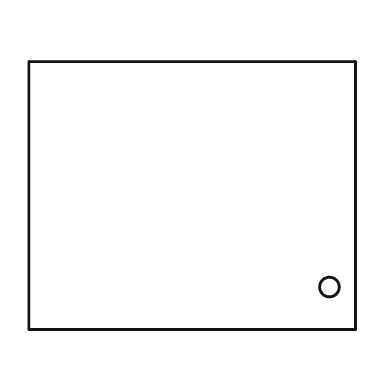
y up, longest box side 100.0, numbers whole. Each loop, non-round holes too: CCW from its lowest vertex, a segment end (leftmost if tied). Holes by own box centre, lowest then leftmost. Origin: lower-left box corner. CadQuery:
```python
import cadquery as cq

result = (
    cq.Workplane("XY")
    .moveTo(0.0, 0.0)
    .lineTo(100.0, 0.0)
    .lineTo(100.0, 82.0)
    .lineTo(0.0, 82.0)
    .close()
    .moveTo(92.0, 13.0)
    .circle(3.0)
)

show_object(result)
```